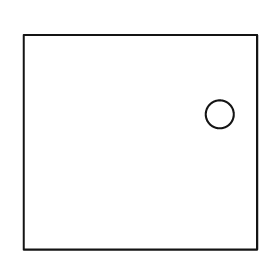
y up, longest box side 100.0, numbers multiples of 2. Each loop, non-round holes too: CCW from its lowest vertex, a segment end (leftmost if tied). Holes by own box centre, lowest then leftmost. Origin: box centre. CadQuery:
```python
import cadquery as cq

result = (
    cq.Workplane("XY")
    .moveTo(-50.0, -46.0)
    .lineTo(50.0, -46.0)
    .lineTo(50.0, 46.0)
    .lineTo(-50.0, 46.0)
    .close()
    .moveTo(34.0, 12.0)
    .circle(6.0)
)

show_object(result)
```